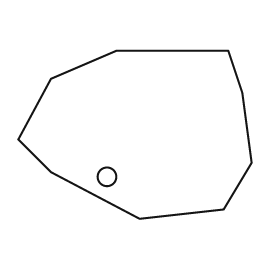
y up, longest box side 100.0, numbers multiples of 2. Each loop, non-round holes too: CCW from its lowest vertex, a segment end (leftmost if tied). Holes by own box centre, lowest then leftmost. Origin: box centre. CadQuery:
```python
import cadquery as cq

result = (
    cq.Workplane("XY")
    .moveTo(2.0, -36.0)
    .lineTo(38.0, -32.0)
    .lineTo(50.0, -12.0)
    .lineTo(46.0, 18.0)
    .lineTo(40.0, 36.0)
    .lineTo(-8.0, 36.0)
    .lineTo(-36.0, 24.0)
    .lineTo(-50.0, -2.0)
    .lineTo(-36.0, -16.0)
    .close()
    .moveTo(-12.0, -18.0)
    .circle(4.0)
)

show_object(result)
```